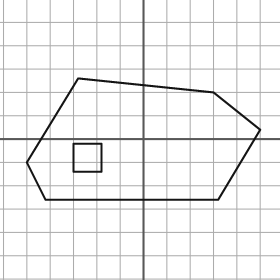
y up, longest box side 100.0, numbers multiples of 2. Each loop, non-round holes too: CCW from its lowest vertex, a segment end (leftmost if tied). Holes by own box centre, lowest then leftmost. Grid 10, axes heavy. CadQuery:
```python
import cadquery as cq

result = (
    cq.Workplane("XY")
    .moveTo(-42.0, -26.0)
    .lineTo(32.0, -26.0)
    .lineTo(50.0, 4.0)
    .lineTo(30.0, 20.0)
    .lineTo(-28.0, 26.0)
    .lineTo(-50.0, -10.0)
    .close()
    .moveTo(-30.0, -14.0)
    .lineTo(-18.0, -14.0)
    .lineTo(-18.0, -2.0)
    .lineTo(-30.0, -2.0)
    .close()
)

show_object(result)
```